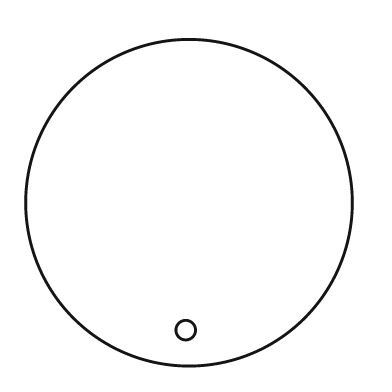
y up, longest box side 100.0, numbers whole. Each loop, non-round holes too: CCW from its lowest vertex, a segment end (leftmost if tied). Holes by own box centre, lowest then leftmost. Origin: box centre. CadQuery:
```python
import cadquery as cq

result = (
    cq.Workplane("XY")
    .moveTo(0.0, 0.0)
    .circle(50.0)
    .moveTo(-1.0, -39.0)
    .circle(3.0)
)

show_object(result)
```